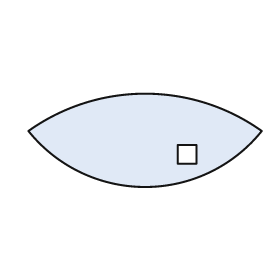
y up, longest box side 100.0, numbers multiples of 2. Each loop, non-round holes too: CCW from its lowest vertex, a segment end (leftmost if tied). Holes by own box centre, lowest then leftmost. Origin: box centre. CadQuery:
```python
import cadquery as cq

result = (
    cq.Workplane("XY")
    .moveTo(-50.0, 4.0)
    .threePointArc((0.0, -20.0), (50.0, 4.0))
    .threePointArc((0.0, 20.0), (-50.0, 4.0))
    .close()
    .moveTo(14.0, -10.0)
    .lineTo(22.0, -10.0)
    .lineTo(22.0, -2.0)
    .lineTo(14.0, -2.0)
    .close()
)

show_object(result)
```